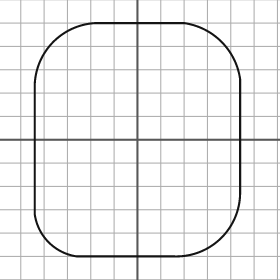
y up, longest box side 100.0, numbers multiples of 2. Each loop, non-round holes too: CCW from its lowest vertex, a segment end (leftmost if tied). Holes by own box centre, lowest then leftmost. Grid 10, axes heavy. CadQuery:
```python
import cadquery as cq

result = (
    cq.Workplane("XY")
    .moveTo(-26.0, -50.0)
    .lineTo(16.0, -50.0)
    .threePointArc((36.0, -42.0), (44.0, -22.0))
    .lineTo(44.0, 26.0)
    .threePointArc((36.0, 42.0), (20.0, 50.0))
    .lineTo(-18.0, 50.0)
    .threePointArc((-36.0, 42.0), (-44.0, 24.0))
    .lineTo(-44.0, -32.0)
    .threePointArc((-38.0, -44.0), (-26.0, -50.0))
    .close()
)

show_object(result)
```